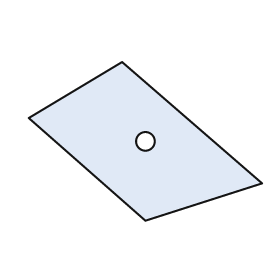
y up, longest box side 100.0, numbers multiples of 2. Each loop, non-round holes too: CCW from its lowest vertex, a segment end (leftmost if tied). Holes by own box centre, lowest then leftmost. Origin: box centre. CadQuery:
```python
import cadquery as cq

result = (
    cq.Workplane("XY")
    .moveTo(0.0, -34.0)
    .lineTo(50.0, -18.0)
    .lineTo(-10.0, 34.0)
    .lineTo(-50.0, 10.0)
    .close()
    .moveTo(0.0, 0.0)
    .circle(4.0)
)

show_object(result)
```